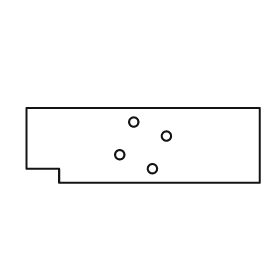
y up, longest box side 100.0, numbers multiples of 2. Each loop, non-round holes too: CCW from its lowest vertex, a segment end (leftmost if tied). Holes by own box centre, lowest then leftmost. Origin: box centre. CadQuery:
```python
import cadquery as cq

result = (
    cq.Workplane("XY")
    .moveTo(-36.0, -16.0)
    .lineTo(50.0, -16.0)
    .lineTo(50.0, 16.0)
    .lineTo(-50.0, 16.0)
    .lineTo(-50.0, -10.0)
    .lineTo(-36.0, -10.0)
    .close()
    .moveTo(4.0, -10.0)
    .circle(2.0)
    .moveTo(-10.0, -4.0)
    .circle(2.0)
    .moveTo(10.0, 4.0)
    .circle(2.0)
    .moveTo(-4.0, 10.0)
    .circle(2.0)
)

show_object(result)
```